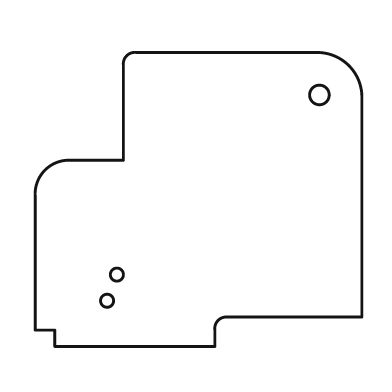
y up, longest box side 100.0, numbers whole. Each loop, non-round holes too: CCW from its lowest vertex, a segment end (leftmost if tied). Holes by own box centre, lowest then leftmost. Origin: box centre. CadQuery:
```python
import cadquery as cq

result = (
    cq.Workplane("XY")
    .moveTo(-44.0, -45.0)
    .lineTo(5.0, -45.0)
    .lineTo(5.0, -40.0)
    .threePointArc((6.0, -37.0), (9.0, -36.0))
    .lineTo(50.0, -36.0)
    .lineTo(50.0, 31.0)
    .threePointArc((46.0, 41.0), (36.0, 45.0))
    .lineTo(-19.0, 45.0)
    .threePointArc((-22.0, 44.0), (-23.0, 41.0))
    .lineTo(-23.0, 12.0)
    .lineTo(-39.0, 12.0)
    .threePointArc((-47.0, 9.0), (-50.0, 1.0))
    .lineTo(-50.0, -40.0)
    .lineTo(-44.0, -40.0)
    .close()
    .moveTo(-28.0, -31.0)
    .circle(2.0)
    .moveTo(-25.0, -23.0)
    .circle(2.0)
    .moveTo(37.0, 32.0)
    .circle(3.0)
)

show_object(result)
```